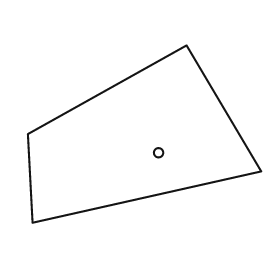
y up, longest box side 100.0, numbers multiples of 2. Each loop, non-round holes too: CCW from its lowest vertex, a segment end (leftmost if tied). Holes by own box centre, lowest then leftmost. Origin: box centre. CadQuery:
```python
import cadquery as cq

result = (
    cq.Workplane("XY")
    .moveTo(-48.0, -38.0)
    .lineTo(50.0, -16.0)
    .lineTo(18.0, 38.0)
    .lineTo(-50.0, 0.0)
    .close()
    .moveTo(6.0, -8.0)
    .circle(2.0)
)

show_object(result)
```